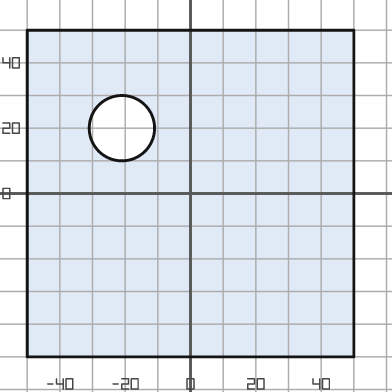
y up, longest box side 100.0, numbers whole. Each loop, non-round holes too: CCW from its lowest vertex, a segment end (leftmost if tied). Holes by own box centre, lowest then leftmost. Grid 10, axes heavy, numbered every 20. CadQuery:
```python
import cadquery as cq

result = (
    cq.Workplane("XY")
    .moveTo(-50.0, -50.0)
    .lineTo(50.0, -50.0)
    .lineTo(50.0, 50.0)
    .lineTo(-50.0, 50.0)
    .close()
    .moveTo(-21.0, 20.0)
    .circle(10.0)
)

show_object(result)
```